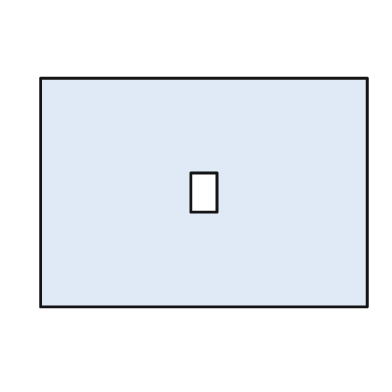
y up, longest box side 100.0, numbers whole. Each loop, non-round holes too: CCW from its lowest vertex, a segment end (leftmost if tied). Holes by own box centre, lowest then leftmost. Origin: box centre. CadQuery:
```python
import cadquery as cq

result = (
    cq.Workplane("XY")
    .moveTo(-50.0, -35.0)
    .lineTo(50.0, -35.0)
    .lineTo(50.0, 35.0)
    .lineTo(-50.0, 35.0)
    .close()
    .moveTo(-4.0, -6.0)
    .lineTo(4.0, -6.0)
    .lineTo(4.0, 6.0)
    .lineTo(-4.0, 6.0)
    .close()
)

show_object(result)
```